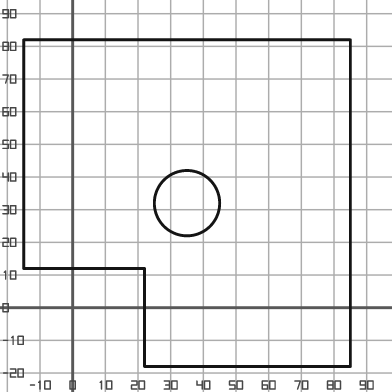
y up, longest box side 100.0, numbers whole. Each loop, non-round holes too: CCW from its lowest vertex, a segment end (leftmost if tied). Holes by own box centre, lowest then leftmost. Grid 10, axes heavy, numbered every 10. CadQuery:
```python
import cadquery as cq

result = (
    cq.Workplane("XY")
    .moveTo(22.0, -18.0)
    .lineTo(85.0, -18.0)
    .lineTo(85.0, 82.0)
    .lineTo(-15.0, 82.0)
    .lineTo(-15.0, 12.0)
    .lineTo(22.0, 12.0)
    .close()
    .moveTo(35.0, 32.0)
    .circle(10.0)
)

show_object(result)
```